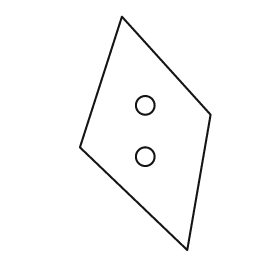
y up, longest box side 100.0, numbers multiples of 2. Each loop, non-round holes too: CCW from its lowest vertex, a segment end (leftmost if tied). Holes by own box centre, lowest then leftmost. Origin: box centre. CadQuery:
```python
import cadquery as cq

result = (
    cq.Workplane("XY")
    .moveTo(18.0, -50.0)
    .lineTo(28.0, 8.0)
    .lineTo(-10.0, 50.0)
    .lineTo(-28.0, -6.0)
    .close()
    .moveTo(0.0, -10.0)
    .circle(4.0)
    .moveTo(0.0, 12.0)
    .circle(4.0)
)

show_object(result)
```